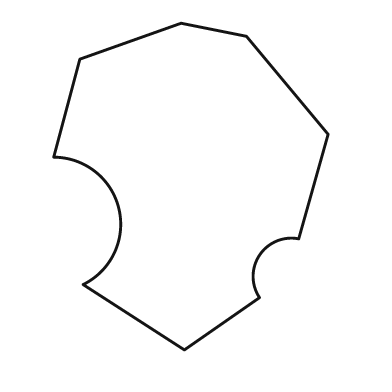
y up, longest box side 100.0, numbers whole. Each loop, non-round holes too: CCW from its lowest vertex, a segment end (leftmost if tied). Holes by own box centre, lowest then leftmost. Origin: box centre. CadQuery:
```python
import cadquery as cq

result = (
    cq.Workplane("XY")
    .moveTo(-2.0, -50.0)
    .lineTo(21.0, -34.0)
    .threePointArc((21.0, -21.0), (33.0, -16.0))
    .lineTo(42.0, 16.0)
    .lineTo(17.0, 46.0)
    .lineTo(-3.0, 50.0)
    .lineTo(-34.0, 39.0)
    .lineTo(-42.0, 9.0)
    .threePointArc((-22.0, -7.0), (-33.0, -30.0))
    .close()
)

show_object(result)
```